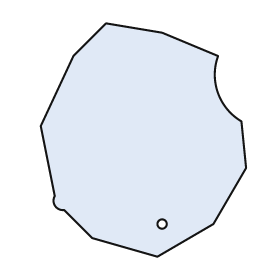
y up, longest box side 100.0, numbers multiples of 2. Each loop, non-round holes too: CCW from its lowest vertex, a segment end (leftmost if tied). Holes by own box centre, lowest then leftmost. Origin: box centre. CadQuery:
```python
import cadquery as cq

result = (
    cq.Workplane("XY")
    .moveTo(6.0, -50.0)
    .lineTo(30.0, -36.0)
    .lineTo(44.0, -12.0)
    .lineTo(42.0, 8.0)
    .threePointArc((32.0, 20.0), (32.0, 36.0))
    .lineTo(8.0, 46.0)
    .lineTo(-16.0, 50.0)
    .lineTo(-30.0, 36.0)
    .lineTo(-44.0, 6.0)
    .lineTo(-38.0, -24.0)
    .threePointArc((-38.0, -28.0), (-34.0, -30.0))
    .lineTo(-22.0, -42.0)
    .close()
    .moveTo(8.0, -36.0)
    .circle(2.0)
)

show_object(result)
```